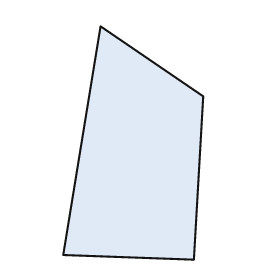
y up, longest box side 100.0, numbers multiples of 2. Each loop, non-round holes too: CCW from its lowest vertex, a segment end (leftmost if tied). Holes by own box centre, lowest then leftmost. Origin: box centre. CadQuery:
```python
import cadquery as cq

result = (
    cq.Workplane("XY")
    .moveTo(26.0, -50.0)
    .lineTo(30.0, 20.0)
    .lineTo(-14.0, 50.0)
    .lineTo(-30.0, -48.0)
    .close()
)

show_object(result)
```